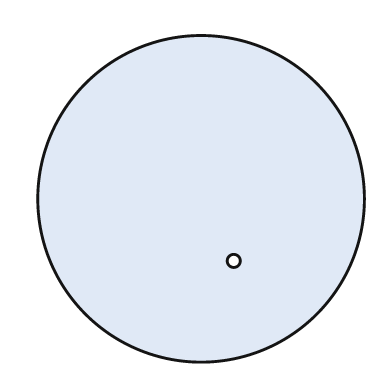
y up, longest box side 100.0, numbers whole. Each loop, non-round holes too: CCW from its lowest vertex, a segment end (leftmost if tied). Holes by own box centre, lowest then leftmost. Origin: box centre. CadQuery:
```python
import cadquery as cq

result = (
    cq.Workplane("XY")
    .moveTo(0.0, 0.0)
    .circle(50.0)
    .moveTo(10.0, -19.0)
    .circle(2.0)
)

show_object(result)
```